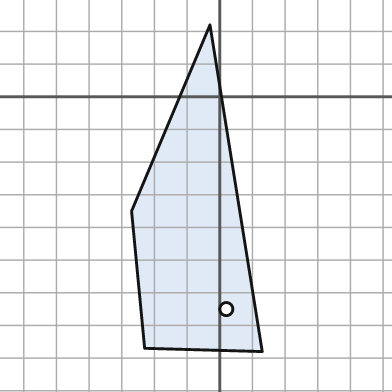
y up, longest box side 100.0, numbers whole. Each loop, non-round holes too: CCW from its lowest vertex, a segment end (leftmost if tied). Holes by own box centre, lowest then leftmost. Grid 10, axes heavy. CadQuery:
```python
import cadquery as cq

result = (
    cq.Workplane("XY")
    .moveTo(13.0, -78.0)
    .lineTo(-3.0, 22.0)
    .lineTo(-27.0, -35.0)
    .lineTo(-23.0, -77.0)
    .close()
    .moveTo(2.0, -65.0)
    .circle(2.0)
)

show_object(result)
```